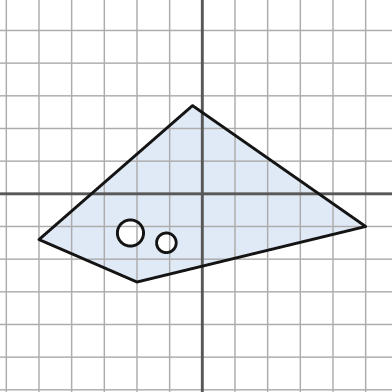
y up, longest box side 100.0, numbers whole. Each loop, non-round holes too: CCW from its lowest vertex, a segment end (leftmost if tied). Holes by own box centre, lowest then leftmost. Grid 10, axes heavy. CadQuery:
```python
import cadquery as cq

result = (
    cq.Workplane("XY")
    .moveTo(-20.0, -27.0)
    .lineTo(50.0, -10.0)
    .lineTo(-3.0, 27.0)
    .lineTo(-50.0, -14.0)
    .close()
    .moveTo(-11.0, -15.0)
    .circle(3.0)
    .moveTo(-22.0, -12.0)
    .circle(4.0)
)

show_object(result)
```